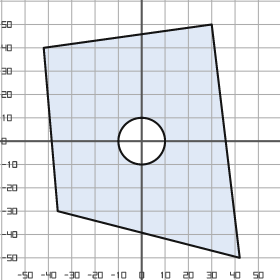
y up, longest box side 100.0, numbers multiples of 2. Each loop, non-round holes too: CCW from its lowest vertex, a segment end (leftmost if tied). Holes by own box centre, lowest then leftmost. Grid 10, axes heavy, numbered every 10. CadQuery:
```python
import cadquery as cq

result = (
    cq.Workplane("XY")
    .moveTo(42.0, -50.0)
    .lineTo(30.0, 50.0)
    .lineTo(-42.0, 40.0)
    .lineTo(-36.0, -30.0)
    .close()
    .moveTo(0.0, 0.0)
    .circle(10.0)
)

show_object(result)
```